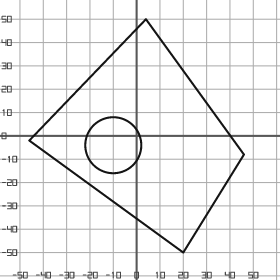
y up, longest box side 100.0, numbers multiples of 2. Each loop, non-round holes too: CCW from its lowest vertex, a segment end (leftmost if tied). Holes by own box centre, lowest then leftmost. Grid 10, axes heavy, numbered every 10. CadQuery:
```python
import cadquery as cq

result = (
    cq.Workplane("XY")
    .moveTo(20.0, -50.0)
    .lineTo(46.0, -8.0)
    .lineTo(4.0, 50.0)
    .lineTo(-46.0, -2.0)
    .close()
    .moveTo(-10.0, -4.0)
    .circle(12.0)
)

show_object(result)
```